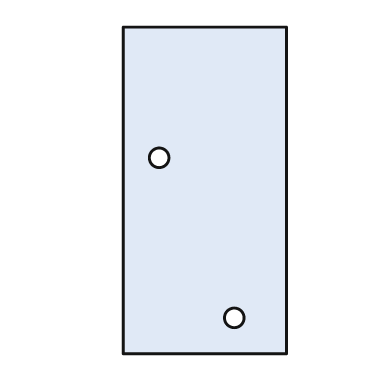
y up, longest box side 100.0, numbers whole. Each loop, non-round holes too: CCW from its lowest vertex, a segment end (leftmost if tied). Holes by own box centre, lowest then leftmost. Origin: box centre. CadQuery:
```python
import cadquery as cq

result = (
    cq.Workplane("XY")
    .moveTo(-25.0, -50.0)
    .lineTo(25.0, -50.0)
    .lineTo(25.0, 50.0)
    .lineTo(-25.0, 50.0)
    .close()
    .moveTo(9.0, -39.0)
    .circle(3.0)
    .moveTo(-14.0, 10.0)
    .circle(3.0)
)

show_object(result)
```